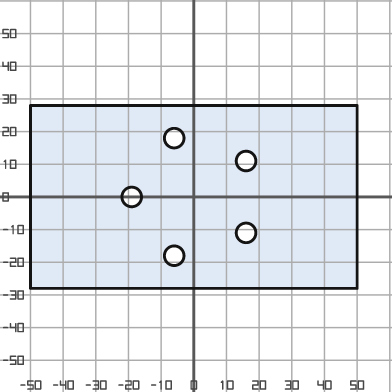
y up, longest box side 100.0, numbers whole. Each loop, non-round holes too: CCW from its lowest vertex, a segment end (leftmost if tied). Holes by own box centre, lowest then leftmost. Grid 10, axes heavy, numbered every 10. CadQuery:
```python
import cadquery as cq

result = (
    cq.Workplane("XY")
    .moveTo(-50.0, -28.0)
    .lineTo(50.0, -28.0)
    .lineTo(50.0, 28.0)
    .lineTo(-50.0, 28.0)
    .close()
    .moveTo(-6.0, -18.0)
    .circle(3.0)
    .moveTo(16.0, -11.0)
    .circle(3.0)
    .moveTo(-19.0, 0.0)
    .circle(3.0)
    .moveTo(16.0, 11.0)
    .circle(3.0)
    .moveTo(-6.0, 18.0)
    .circle(3.0)
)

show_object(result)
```